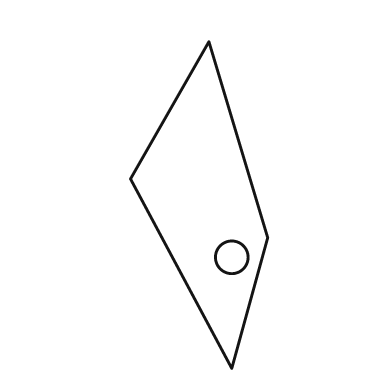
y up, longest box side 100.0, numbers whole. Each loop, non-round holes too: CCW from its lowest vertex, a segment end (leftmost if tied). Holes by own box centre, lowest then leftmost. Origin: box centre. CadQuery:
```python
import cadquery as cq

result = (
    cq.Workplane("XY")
    .moveTo(10.0, -50.0)
    .lineTo(21.0, -10.0)
    .lineTo(3.0, 50.0)
    .lineTo(-21.0, 8.0)
    .close()
    .moveTo(10.0, -16.0)
    .circle(5.0)
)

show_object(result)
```